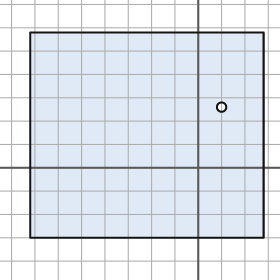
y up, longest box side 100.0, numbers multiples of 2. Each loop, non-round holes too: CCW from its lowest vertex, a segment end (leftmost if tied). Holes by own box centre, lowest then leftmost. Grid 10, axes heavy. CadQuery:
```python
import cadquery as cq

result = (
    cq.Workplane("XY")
    .moveTo(-72.0, -30.0)
    .lineTo(28.0, -30.0)
    .lineTo(28.0, 58.0)
    .lineTo(-72.0, 58.0)
    .close()
    .moveTo(10.0, 26.0)
    .circle(2.0)
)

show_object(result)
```